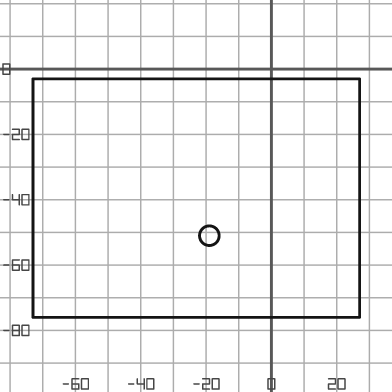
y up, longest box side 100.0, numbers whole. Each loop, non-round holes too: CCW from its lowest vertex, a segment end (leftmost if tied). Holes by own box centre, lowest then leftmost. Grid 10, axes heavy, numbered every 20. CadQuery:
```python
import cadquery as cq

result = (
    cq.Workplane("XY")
    .moveTo(-73.0, -76.0)
    .lineTo(27.0, -76.0)
    .lineTo(27.0, -3.0)
    .lineTo(-73.0, -3.0)
    .close()
    .moveTo(-19.0, -51.0)
    .circle(3.0)
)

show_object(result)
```